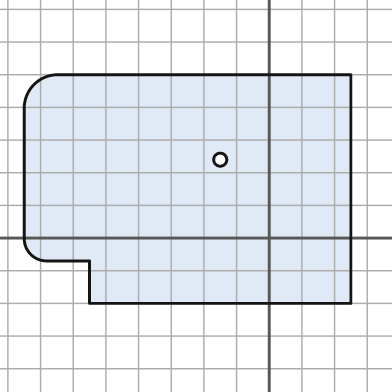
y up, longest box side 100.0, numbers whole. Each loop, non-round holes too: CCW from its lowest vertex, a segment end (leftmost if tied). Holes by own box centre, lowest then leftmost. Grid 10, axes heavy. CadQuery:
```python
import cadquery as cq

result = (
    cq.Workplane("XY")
    .moveTo(-55.0, -20.0)
    .lineTo(25.0, -20.0)
    .lineTo(25.0, 50.0)
    .lineTo(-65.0, 50.0)
    .threePointArc((-72.0, 47.0), (-75.0, 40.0))
    .lineTo(-75.0, 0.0)
    .threePointArc((-73.0, -5.0), (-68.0, -7.0))
    .lineTo(-55.0, -7.0)
    .close()
    .moveTo(-15.0, 24.0)
    .circle(2.0)
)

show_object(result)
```